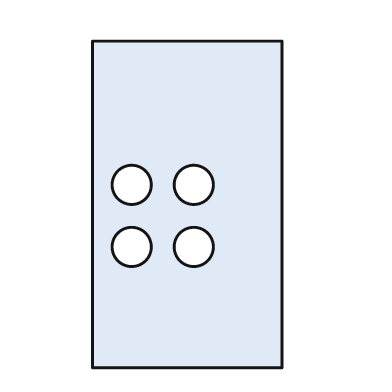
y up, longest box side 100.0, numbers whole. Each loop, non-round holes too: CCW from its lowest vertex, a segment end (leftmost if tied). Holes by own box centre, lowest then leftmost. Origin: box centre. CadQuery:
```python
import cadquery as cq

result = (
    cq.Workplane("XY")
    .moveTo(-29.0, -50.0)
    .lineTo(29.0, -50.0)
    .lineTo(29.0, 50.0)
    .lineTo(-29.0, 50.0)
    .close()
    .moveTo(-17.0, -13.0)
    .circle(6.0)
    .moveTo(2.0, -13.0)
    .circle(6.0)
    .moveTo(-17.0, 6.0)
    .circle(6.0)
    .moveTo(2.0, 6.0)
    .circle(6.0)
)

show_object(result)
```